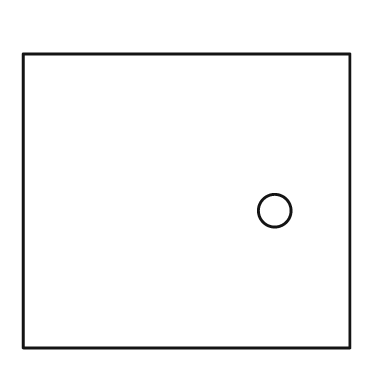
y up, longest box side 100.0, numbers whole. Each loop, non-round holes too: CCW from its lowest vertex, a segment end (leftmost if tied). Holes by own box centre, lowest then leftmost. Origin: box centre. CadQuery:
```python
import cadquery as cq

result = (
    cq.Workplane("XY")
    .moveTo(-50.0, -45.0)
    .lineTo(50.0, -45.0)
    .lineTo(50.0, 45.0)
    .lineTo(-50.0, 45.0)
    .close()
    .moveTo(27.0, -3.0)
    .circle(5.0)
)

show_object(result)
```